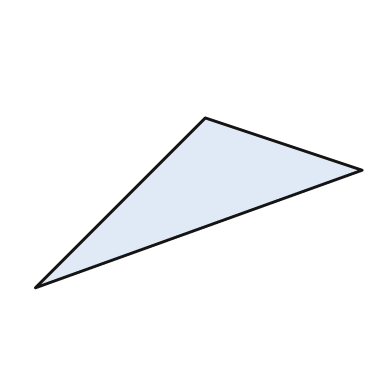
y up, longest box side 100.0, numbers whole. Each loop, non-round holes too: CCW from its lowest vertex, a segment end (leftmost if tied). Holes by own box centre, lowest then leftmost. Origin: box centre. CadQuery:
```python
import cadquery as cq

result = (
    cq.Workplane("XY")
    .moveTo(-50.0, -26.0)
    .lineTo(50.0, 10.0)
    .lineTo(2.0, 26.0)
    .close()
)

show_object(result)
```